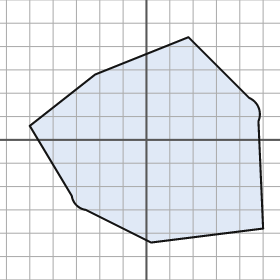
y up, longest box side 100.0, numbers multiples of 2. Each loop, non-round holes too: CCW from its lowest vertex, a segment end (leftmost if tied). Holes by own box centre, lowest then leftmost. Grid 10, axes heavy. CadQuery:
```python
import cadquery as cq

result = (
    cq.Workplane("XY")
    .moveTo(2.0, -44.0)
    .lineTo(50.0, -38.0)
    .lineTo(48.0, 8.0)
    .threePointArc((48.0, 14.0), (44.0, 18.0))
    .lineTo(18.0, 44.0)
    .lineTo(-22.0, 28.0)
    .lineTo(-50.0, 6.0)
    .lineTo(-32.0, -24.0)
    .threePointArc((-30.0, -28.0), (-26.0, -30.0))
    .close()
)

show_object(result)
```